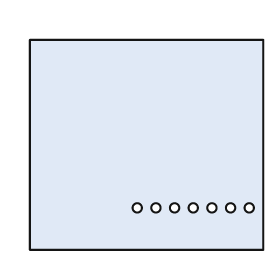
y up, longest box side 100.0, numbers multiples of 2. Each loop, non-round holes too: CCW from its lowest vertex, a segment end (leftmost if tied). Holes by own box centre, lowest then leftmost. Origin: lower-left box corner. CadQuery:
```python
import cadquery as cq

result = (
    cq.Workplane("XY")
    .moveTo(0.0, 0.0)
    .lineTo(100.0, 0.0)
    .lineTo(100.0, 90.0)
    .lineTo(0.0, 90.0)
    .close()
    .moveTo(46.0, 18.0)
    .circle(2.0)
    .moveTo(54.0, 18.0)
    .circle(2.0)
    .moveTo(62.0, 18.0)
    .circle(2.0)
    .moveTo(70.0, 18.0)
    .circle(2.0)
    .moveTo(78.0, 18.0)
    .circle(2.0)
    .moveTo(86.0, 18.0)
    .circle(2.0)
    .moveTo(94.0, 18.0)
    .circle(2.0)
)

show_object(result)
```